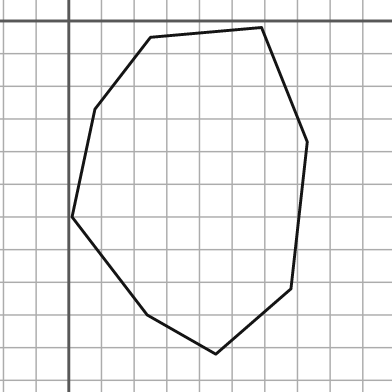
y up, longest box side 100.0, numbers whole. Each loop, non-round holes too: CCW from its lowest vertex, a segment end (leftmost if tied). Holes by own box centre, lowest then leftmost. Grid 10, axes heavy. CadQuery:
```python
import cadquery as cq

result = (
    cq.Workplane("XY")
    .moveTo(45.0, -102.0)
    .lineTo(68.0, -82.0)
    .lineTo(73.0, -37.0)
    .lineTo(59.0, -2.0)
    .lineTo(25.0, -5.0)
    .lineTo(8.0, -27.0)
    .lineTo(1.0, -60.0)
    .lineTo(24.0, -90.0)
    .close()
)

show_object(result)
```